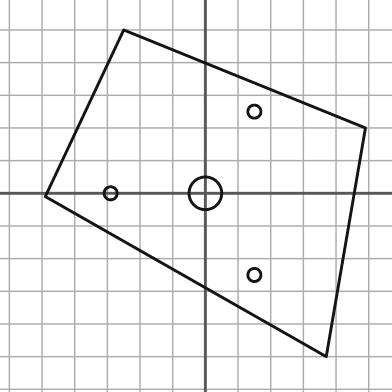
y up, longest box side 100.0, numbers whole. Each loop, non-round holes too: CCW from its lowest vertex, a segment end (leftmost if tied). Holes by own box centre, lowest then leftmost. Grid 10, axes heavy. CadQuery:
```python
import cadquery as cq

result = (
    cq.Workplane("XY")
    .moveTo(37.0, -50.0)
    .lineTo(49.0, 20.0)
    .lineTo(-25.0, 50.0)
    .lineTo(-49.0, -1.0)
    .close()
    .moveTo(15.0, -25.0)
    .circle(2.0)
    .moveTo(-29.0, 0.0)
    .circle(2.0)
    .moveTo(0.0, 0.0)
    .circle(5.0)
    .moveTo(15.0, 25.0)
    .circle(2.0)
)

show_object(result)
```